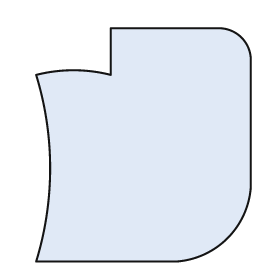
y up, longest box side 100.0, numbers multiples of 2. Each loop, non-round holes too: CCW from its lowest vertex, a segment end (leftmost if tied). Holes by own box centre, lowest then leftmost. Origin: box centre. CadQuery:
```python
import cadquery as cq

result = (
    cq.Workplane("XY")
    .moveTo(-46.0, -50.0)
    .lineTo(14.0, -50.0)
    .threePointArc((36.0, -40.0), (46.0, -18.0))
    .lineTo(46.0, 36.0)
    .threePointArc((42.0, 46.0), (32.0, 50.0))
    .lineTo(-14.0, 50.0)
    .lineTo(-14.0, 30.0)
    .threePointArc((-30.0, 32.0), (-46.0, 30.0))
    .threePointArc((-40.0, -10.0), (-46.0, -50.0))
    .close()
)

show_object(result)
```